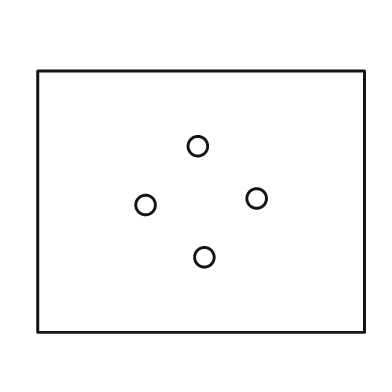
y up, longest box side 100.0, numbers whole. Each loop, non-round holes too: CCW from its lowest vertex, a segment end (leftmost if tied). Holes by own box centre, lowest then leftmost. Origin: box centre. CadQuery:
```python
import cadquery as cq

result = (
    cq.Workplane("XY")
    .moveTo(-50.0, -40.0)
    .lineTo(50.0, -40.0)
    .lineTo(50.0, 40.0)
    .lineTo(-50.0, 40.0)
    .close()
    .moveTo(1.0, -17.0)
    .circle(3.0)
    .moveTo(-17.0, -1.0)
    .circle(3.0)
    .moveTo(17.0, 1.0)
    .circle(3.0)
    .moveTo(-1.0, 17.0)
    .circle(3.0)
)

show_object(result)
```